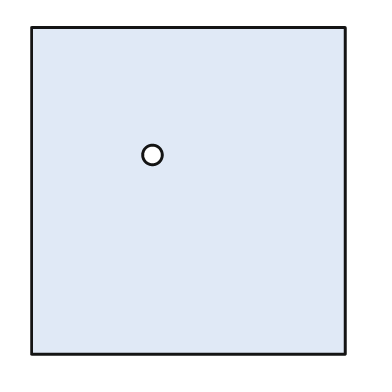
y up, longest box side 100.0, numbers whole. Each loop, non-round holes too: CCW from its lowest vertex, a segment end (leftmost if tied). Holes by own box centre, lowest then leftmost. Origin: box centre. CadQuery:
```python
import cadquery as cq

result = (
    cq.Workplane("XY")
    .moveTo(-48.0, -50.0)
    .lineTo(48.0, -50.0)
    .lineTo(48.0, 50.0)
    .lineTo(-48.0, 50.0)
    .close()
    .moveTo(-11.0, 11.0)
    .circle(3.0)
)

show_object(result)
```